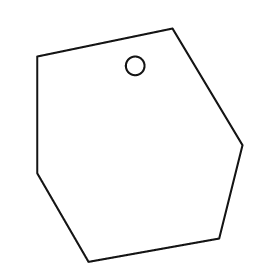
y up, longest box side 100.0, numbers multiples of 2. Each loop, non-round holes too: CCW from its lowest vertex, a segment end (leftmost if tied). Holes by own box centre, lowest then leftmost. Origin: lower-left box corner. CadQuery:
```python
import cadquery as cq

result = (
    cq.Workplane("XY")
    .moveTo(22.0, 0.0)
    .lineTo(78.0, 10.0)
    .lineTo(88.0, 50.0)
    .lineTo(58.0, 100.0)
    .lineTo(0.0, 88.0)
    .lineTo(0.0, 38.0)
    .close()
    .moveTo(42.0, 84.0)
    .circle(4.0)
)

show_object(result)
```